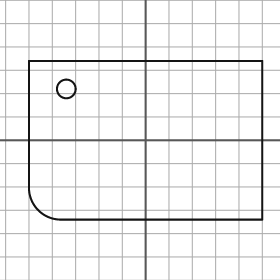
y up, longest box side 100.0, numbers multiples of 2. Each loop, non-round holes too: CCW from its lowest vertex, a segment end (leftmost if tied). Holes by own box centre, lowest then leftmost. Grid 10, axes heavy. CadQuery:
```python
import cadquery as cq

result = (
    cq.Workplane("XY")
    .moveTo(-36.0, -34.0)
    .lineTo(50.0, -34.0)
    .lineTo(50.0, 34.0)
    .lineTo(-50.0, 34.0)
    .lineTo(-50.0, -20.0)
    .threePointArc((-46.0, -30.0), (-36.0, -34.0))
    .close()
    .moveTo(-34.0, 22.0)
    .circle(4.0)
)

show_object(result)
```